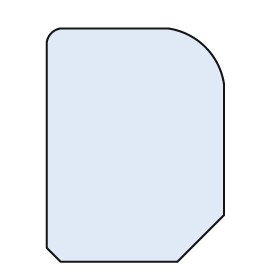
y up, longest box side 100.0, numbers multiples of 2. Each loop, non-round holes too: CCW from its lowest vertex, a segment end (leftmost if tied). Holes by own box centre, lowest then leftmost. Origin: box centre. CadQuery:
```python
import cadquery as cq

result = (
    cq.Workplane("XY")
    .moveTo(-32.0, -50.0)
    .lineTo(18.0, -50.0)
    .lineTo(38.0, -30.0)
    .lineTo(38.0, 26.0)
    .threePointArc((30.0, 42.0), (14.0, 50.0))
    .lineTo(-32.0, 50.0)
    .threePointArc((-36.0, 48.0), (-38.0, 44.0))
    .lineTo(-38.0, -44.0)
    .close()
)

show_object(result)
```